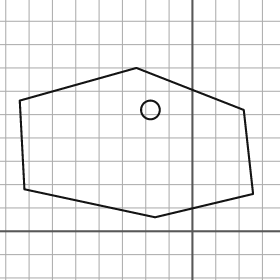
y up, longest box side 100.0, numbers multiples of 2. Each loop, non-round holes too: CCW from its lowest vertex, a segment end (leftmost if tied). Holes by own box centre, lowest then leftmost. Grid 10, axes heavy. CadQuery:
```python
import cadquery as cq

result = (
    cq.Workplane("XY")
    .moveTo(-16.0, 6.0)
    .lineTo(26.0, 16.0)
    .lineTo(22.0, 52.0)
    .lineTo(-24.0, 70.0)
    .lineTo(-74.0, 56.0)
    .lineTo(-72.0, 18.0)
    .close()
    .moveTo(-18.0, 52.0)
    .circle(4.0)
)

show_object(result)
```